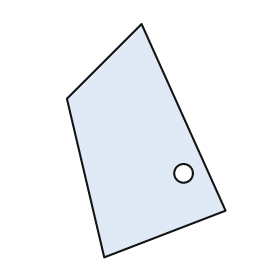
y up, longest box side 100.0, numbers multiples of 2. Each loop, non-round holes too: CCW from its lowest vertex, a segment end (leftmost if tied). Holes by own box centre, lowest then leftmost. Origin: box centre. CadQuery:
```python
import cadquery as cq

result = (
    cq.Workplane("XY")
    .moveTo(-18.0, -50.0)
    .lineTo(34.0, -30.0)
    .lineTo(-2.0, 50.0)
    .lineTo(-34.0, 18.0)
    .close()
    .moveTo(16.0, -14.0)
    .circle(4.0)
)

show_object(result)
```